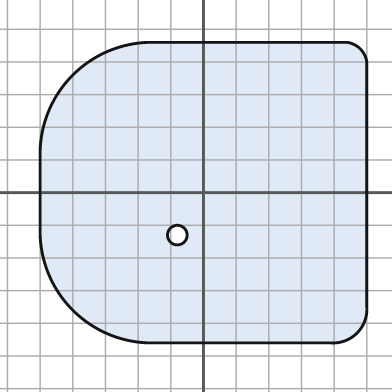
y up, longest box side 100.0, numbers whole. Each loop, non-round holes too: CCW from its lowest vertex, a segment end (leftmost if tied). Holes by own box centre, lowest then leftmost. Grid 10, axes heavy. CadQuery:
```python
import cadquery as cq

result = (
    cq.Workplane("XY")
    .moveTo(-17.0, -46.0)
    .lineTo(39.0, -46.0)
    .threePointArc((47.0, -43.0), (50.0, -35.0))
    .lineTo(50.0, 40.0)
    .threePointArc((48.0, 44.0), (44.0, 46.0))
    .lineTo(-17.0, 46.0)
    .threePointArc((-40.0, 36.0), (-50.0, 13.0))
    .lineTo(-50.0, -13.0)
    .threePointArc((-40.0, -36.0), (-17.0, -46.0))
    .close()
    .moveTo(-8.0, -13.0)
    .circle(3.0)
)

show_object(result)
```